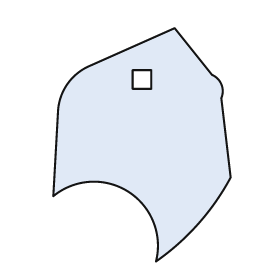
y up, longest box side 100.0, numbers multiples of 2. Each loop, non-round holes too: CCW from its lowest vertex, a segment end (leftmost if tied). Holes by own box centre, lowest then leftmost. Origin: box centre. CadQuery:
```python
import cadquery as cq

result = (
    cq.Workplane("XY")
    .moveTo(6.0, -50.0)
    .threePointArc((24.0, -34.0), (38.0, -14.0))
    .lineTo(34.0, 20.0)
    .threePointArc((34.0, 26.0), (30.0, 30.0))
    .lineTo(14.0, 50.0)
    .lineTo(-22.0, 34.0)
    .threePointArc((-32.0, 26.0), (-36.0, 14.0))
    .lineTo(-38.0, -22.0)
    .threePointArc((-6.0, -20.0), (6.0, -50.0))
    .close()
    .moveTo(-4.0, 24.0)
    .lineTo(4.0, 24.0)
    .lineTo(4.0, 32.0)
    .lineTo(-4.0, 32.0)
    .close()
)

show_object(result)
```